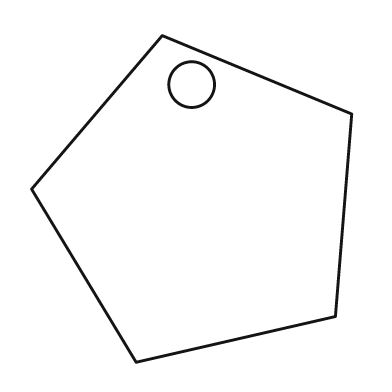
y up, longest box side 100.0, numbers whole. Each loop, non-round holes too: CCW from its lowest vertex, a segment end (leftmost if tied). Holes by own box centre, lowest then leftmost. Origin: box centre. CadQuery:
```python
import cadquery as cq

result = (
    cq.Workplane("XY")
    .moveTo(-17.0, -50.0)
    .lineTo(44.0, -36.0)
    .lineTo(49.0, 26.0)
    .lineTo(-9.0, 50.0)
    .lineTo(-49.0, 3.0)
    .close()
    .moveTo(0.0, 35.0)
    .circle(7.0)
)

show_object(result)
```